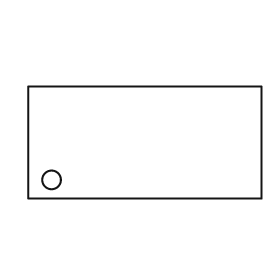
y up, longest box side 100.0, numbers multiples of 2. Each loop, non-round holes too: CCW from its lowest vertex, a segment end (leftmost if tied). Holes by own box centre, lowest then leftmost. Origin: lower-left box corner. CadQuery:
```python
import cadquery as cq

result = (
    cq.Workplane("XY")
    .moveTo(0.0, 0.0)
    .lineTo(100.0, 0.0)
    .lineTo(100.0, 48.0)
    .lineTo(0.0, 48.0)
    .close()
    .moveTo(10.0, 8.0)
    .circle(4.0)
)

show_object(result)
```